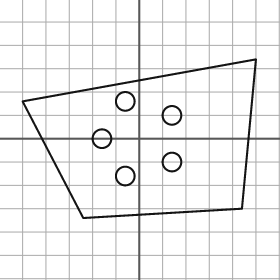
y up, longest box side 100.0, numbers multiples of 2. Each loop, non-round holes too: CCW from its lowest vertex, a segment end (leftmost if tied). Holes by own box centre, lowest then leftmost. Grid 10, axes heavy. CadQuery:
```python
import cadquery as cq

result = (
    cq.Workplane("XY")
    .moveTo(-24.0, -34.0)
    .lineTo(44.0, -30.0)
    .lineTo(50.0, 34.0)
    .lineTo(-50.0, 16.0)
    .close()
    .moveTo(-6.0, -16.0)
    .circle(4.0)
    .moveTo(14.0, -10.0)
    .circle(4.0)
    .moveTo(-16.0, 0.0)
    .circle(4.0)
    .moveTo(14.0, 10.0)
    .circle(4.0)
    .moveTo(-6.0, 16.0)
    .circle(4.0)
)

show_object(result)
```